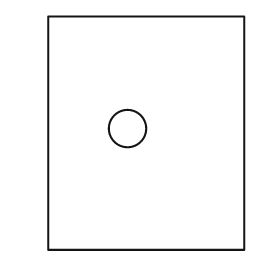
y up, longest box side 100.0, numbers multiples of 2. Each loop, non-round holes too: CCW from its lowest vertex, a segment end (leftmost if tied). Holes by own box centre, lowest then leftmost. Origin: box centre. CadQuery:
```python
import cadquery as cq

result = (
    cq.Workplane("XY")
    .moveTo(-42.0, -50.0)
    .lineTo(42.0, -50.0)
    .lineTo(42.0, 50.0)
    .lineTo(-42.0, 50.0)
    .close()
    .moveTo(-8.0, 2.0)
    .circle(8.0)
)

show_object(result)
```